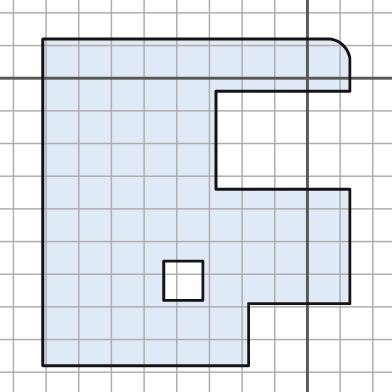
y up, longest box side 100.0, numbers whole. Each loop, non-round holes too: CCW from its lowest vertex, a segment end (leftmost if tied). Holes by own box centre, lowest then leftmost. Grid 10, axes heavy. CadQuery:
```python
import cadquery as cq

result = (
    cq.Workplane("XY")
    .moveTo(-81.0, -88.0)
    .lineTo(-18.0, -88.0)
    .lineTo(-18.0, -69.0)
    .lineTo(13.0, -69.0)
    .lineTo(13.0, -34.0)
    .lineTo(-28.0, -34.0)
    .lineTo(-28.0, -4.0)
    .lineTo(13.0, -4.0)
    .lineTo(13.0, 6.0)
    .threePointArc((11.0, 10.0), (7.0, 12.0))
    .lineTo(-81.0, 12.0)
    .close()
    .moveTo(-44.0, -68.0)
    .lineTo(-32.0, -68.0)
    .lineTo(-32.0, -56.0)
    .lineTo(-44.0, -56.0)
    .close()
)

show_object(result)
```